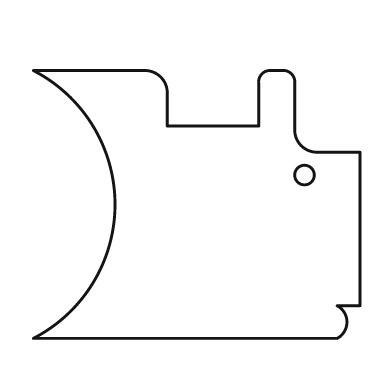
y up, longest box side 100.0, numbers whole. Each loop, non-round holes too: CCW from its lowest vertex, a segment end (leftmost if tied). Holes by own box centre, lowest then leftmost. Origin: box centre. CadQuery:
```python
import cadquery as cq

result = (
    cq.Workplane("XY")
    .moveTo(-50.0, -41.0)
    .lineTo(43.0, -41.0)
    .threePointArc((46.0, -36.0), (43.0, -31.0))
    .lineTo(50.0, -31.0)
    .lineTo(50.0, 16.0)
    .lineTo(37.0, 16.0)
    .threePointArc((32.0, 18.0), (30.0, 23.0))
    .lineTo(30.0, 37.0)
    .threePointArc((29.0, 40.0), (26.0, 41.0))
    .lineTo(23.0, 41.0)
    .threePointArc((20.0, 40.0), (19.0, 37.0))
    .lineTo(19.0, 24.0)
    .lineTo(-9.0, 24.0)
    .lineTo(-9.0, 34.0)
    .threePointArc((-11.0, 39.0), (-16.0, 41.0))
    .lineTo(-50.0, 41.0)
    .threePointArc((-25.0, 0.0), (-50.0, -41.0))
    .close()
    .moveTo(33.0, 9.0)
    .circle(3.0)
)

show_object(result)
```